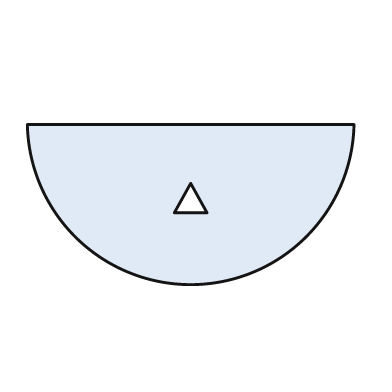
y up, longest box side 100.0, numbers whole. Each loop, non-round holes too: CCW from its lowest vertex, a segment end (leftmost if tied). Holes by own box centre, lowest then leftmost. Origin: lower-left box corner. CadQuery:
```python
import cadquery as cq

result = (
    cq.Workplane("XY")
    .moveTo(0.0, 49.0)
    .threePointArc((50.0, 0.0), (100.0, 49.0))
    .close()
    .moveTo(45.0, 22.0)
    .lineTo(55.0, 22.0)
    .lineTo(50.0, 31.0)
    .close()
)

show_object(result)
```